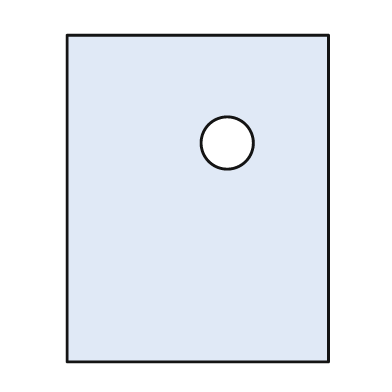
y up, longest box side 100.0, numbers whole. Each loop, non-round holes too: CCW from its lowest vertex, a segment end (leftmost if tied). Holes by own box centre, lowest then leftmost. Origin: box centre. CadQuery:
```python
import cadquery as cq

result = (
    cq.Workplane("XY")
    .moveTo(-40.0, -50.0)
    .lineTo(40.0, -50.0)
    .lineTo(40.0, 50.0)
    .lineTo(-40.0, 50.0)
    .close()
    .moveTo(9.0, 17.0)
    .circle(8.0)
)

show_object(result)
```